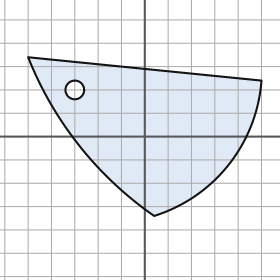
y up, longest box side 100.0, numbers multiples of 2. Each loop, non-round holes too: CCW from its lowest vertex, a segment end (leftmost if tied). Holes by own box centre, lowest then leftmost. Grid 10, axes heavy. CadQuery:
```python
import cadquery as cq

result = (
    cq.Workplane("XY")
    .moveTo(4.0, -34.0)
    .threePointArc((36.0, -12.0), (50.0, 24.0))
    .lineTo(-50.0, 34.0)
    .threePointArc((-28.0, -4.0), (4.0, -34.0))
    .close()
    .moveTo(-30.0, 20.0)
    .circle(4.0)
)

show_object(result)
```